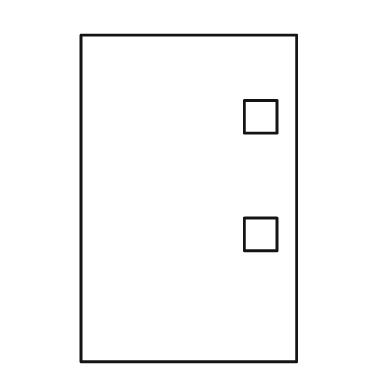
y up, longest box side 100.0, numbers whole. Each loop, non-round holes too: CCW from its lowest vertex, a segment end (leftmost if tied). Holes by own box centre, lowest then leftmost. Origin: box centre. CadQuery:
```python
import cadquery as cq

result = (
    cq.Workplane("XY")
    .moveTo(-33.0, -50.0)
    .lineTo(33.0, -50.0)
    .lineTo(33.0, 50.0)
    .lineTo(-33.0, 50.0)
    .close()
    .moveTo(17.0, -16.0)
    .lineTo(27.0, -16.0)
    .lineTo(27.0, -6.0)
    .lineTo(17.0, -6.0)
    .close()
    .moveTo(17.0, 20.0)
    .lineTo(27.0, 20.0)
    .lineTo(27.0, 30.0)
    .lineTo(17.0, 30.0)
    .close()
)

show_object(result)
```